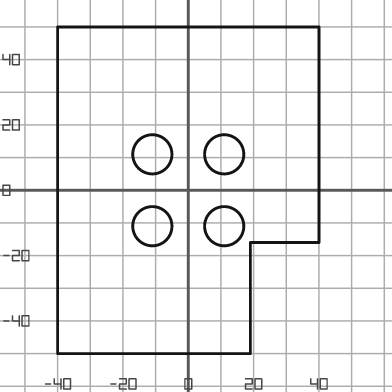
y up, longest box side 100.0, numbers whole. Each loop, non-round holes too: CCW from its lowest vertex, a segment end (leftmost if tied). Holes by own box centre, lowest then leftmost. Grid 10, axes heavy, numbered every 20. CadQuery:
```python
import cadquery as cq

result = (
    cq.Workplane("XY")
    .moveTo(-40.0, -50.0)
    .lineTo(19.0, -50.0)
    .lineTo(19.0, -16.0)
    .lineTo(40.0, -16.0)
    .lineTo(40.0, 50.0)
    .lineTo(-40.0, 50.0)
    .close()
    .moveTo(-11.0, -11.0)
    .circle(6.0)
    .moveTo(11.0, -11.0)
    .circle(6.0)
    .moveTo(-11.0, 11.0)
    .circle(6.0)
    .moveTo(11.0, 11.0)
    .circle(6.0)
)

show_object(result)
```